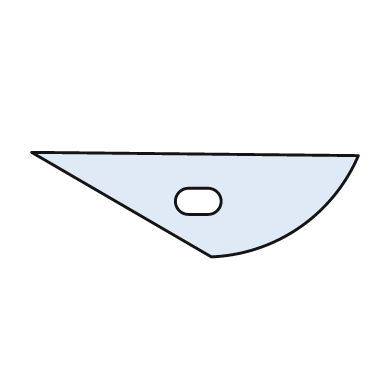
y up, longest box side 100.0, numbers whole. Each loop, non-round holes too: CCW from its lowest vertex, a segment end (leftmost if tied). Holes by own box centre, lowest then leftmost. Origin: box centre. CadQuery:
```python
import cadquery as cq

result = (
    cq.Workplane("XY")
    .moveTo(5.0, -16.0)
    .threePointArc((32.0, -7.0), (50.0, 15.0))
    .lineTo(-50.0, 16.0)
    .close()
    .moveTo(-2.0, -3.0)
    .lineTo(4.0, -3.0)
    .threePointArc((8.0, 1.0), (4.0, 5.0))
    .lineTo(-2.0, 5.0)
    .threePointArc((-6.0, 1.0), (-2.0, -3.0))
    .close()
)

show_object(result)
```